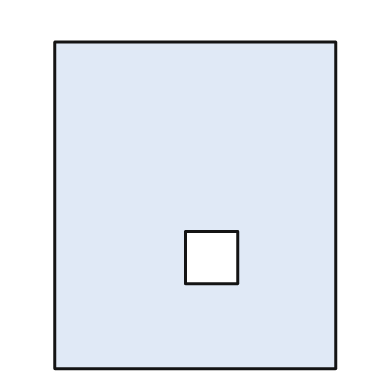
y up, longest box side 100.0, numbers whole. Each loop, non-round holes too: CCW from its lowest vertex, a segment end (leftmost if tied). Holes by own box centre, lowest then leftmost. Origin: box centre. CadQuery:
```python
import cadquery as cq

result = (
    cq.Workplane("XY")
    .moveTo(-43.0, -50.0)
    .lineTo(43.0, -50.0)
    .lineTo(43.0, 50.0)
    .lineTo(-43.0, 50.0)
    .close()
    .moveTo(-3.0, -24.0)
    .lineTo(13.0, -24.0)
    .lineTo(13.0, -8.0)
    .lineTo(-3.0, -8.0)
    .close()
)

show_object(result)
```